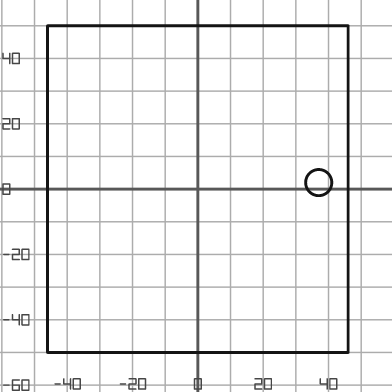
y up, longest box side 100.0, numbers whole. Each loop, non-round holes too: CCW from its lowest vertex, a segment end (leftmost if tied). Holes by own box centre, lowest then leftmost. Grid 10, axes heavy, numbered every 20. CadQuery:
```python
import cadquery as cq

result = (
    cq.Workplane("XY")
    .moveTo(-46.0, -50.0)
    .lineTo(46.0, -50.0)
    .lineTo(46.0, 50.0)
    .lineTo(-46.0, 50.0)
    .close()
    .moveTo(37.0, 2.0)
    .circle(4.0)
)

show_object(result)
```